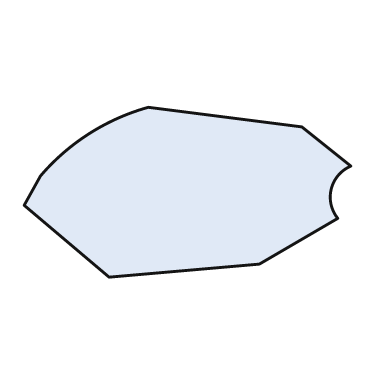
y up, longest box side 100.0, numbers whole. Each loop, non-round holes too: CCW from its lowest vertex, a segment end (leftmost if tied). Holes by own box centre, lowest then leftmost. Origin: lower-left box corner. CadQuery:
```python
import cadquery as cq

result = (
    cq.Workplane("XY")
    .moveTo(26.0, 0.0)
    .lineTo(72.0, 4.0)
    .lineTo(96.0, 18.0)
    .threePointArc((94.0, 27.0), (100.0, 34.0))
    .lineTo(85.0, 46.0)
    .lineTo(38.0, 52.0)
    .threePointArc((20.0, 44.0), (5.0, 31.0))
    .lineTo(0.0, 22.0)
    .close()
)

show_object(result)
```